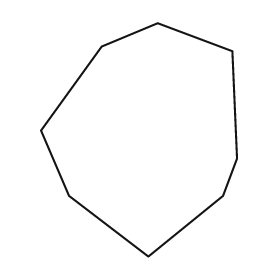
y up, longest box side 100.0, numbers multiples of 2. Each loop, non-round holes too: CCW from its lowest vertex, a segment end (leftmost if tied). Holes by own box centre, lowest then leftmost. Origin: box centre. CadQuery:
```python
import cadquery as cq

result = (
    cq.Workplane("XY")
    .moveTo(4.0, -50.0)
    .lineTo(36.0, -24.0)
    .lineTo(42.0, -8.0)
    .lineTo(40.0, 38.0)
    .lineTo(8.0, 50.0)
    .lineTo(-16.0, 40.0)
    .lineTo(-42.0, 4.0)
    .lineTo(-30.0, -24.0)
    .close()
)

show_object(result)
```